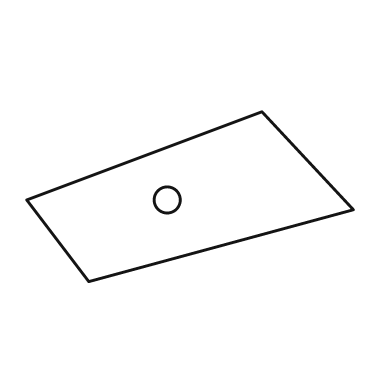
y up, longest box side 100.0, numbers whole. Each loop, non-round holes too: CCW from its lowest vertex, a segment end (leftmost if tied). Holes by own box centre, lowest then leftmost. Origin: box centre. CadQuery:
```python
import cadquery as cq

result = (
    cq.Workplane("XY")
    .moveTo(-31.0, -26.0)
    .lineTo(50.0, -4.0)
    .lineTo(22.0, 26.0)
    .lineTo(-50.0, -1.0)
    .close()
    .moveTo(-7.0, -1.0)
    .circle(4.0)
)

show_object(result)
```